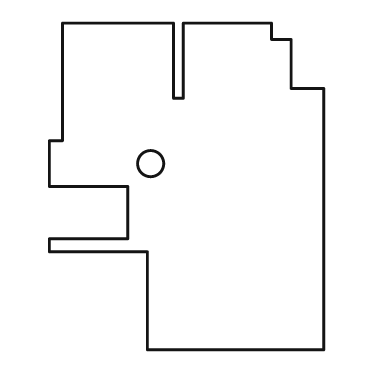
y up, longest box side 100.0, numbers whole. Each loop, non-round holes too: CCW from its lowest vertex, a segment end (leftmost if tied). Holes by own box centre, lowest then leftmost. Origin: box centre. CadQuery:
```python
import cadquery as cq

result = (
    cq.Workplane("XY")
    .moveTo(-12.0, -50.0)
    .lineTo(42.0, -50.0)
    .lineTo(42.0, 30.0)
    .lineTo(32.0, 30.0)
    .lineTo(32.0, 45.0)
    .lineTo(26.0, 45.0)
    .lineTo(26.0, 50.0)
    .lineTo(-1.0, 50.0)
    .lineTo(-1.0, 27.0)
    .lineTo(-4.0, 27.0)
    .lineTo(-4.0, 50.0)
    .lineTo(-38.0, 50.0)
    .lineTo(-38.0, 14.0)
    .lineTo(-42.0, 14.0)
    .lineTo(-42.0, 0.0)
    .lineTo(-18.0, 0.0)
    .lineTo(-18.0, -16.0)
    .lineTo(-42.0, -16.0)
    .lineTo(-42.0, -20.0)
    .lineTo(-12.0, -20.0)
    .close()
    .moveTo(-11.0, 7.0)
    .circle(4.0)
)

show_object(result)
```